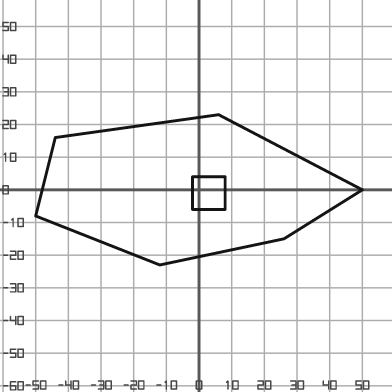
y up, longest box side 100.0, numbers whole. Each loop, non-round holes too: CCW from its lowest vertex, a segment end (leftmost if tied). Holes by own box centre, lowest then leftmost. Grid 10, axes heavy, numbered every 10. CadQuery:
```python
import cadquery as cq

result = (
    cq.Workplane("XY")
    .moveTo(-12.0, -23.0)
    .lineTo(26.0, -15.0)
    .lineTo(50.0, 0.0)
    .lineTo(6.0, 23.0)
    .lineTo(-44.0, 16.0)
    .lineTo(-50.0, -8.0)
    .close()
    .moveTo(-2.0, -6.0)
    .lineTo(8.0, -6.0)
    .lineTo(8.0, 4.0)
    .lineTo(-2.0, 4.0)
    .close()
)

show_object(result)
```